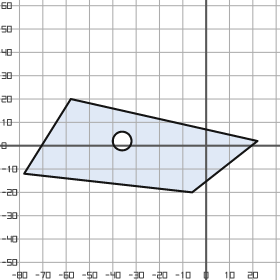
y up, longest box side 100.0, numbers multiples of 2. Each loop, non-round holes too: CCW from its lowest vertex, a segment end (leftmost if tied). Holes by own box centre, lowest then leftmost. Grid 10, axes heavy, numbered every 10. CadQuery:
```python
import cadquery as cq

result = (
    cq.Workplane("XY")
    .moveTo(-6.0, -20.0)
    .lineTo(22.0, 2.0)
    .lineTo(-58.0, 20.0)
    .lineTo(-78.0, -12.0)
    .close()
    .moveTo(-36.0, 2.0)
    .circle(4.0)
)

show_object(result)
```